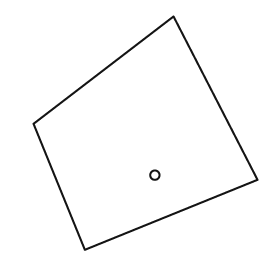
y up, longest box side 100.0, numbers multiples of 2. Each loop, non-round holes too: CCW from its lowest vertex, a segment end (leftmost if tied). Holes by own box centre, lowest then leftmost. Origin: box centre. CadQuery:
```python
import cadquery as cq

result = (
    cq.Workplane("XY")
    .moveTo(-26.0, -50.0)
    .lineTo(48.0, -20.0)
    .lineTo(12.0, 50.0)
    .lineTo(-48.0, 4.0)
    .close()
    .moveTo(4.0, -18.0)
    .circle(2.0)
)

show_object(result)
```